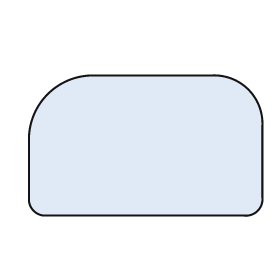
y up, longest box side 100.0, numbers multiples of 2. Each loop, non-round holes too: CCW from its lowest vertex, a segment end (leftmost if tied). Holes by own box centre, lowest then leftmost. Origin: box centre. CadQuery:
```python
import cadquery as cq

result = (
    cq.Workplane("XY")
    .moveTo(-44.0, -30.0)
    .lineTo(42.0, -30.0)
    .threePointArc((48.0, -28.0), (50.0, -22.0))
    .lineTo(50.0, 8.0)
    .threePointArc((44.0, 24.0), (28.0, 30.0))
    .lineTo(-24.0, 30.0)
    .threePointArc((-42.0, 22.0), (-50.0, 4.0))
    .lineTo(-50.0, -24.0)
    .threePointArc((-48.0, -28.0), (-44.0, -30.0))
    .close()
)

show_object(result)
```